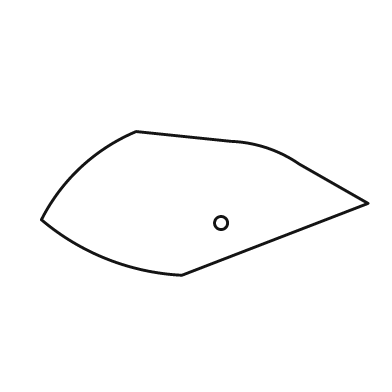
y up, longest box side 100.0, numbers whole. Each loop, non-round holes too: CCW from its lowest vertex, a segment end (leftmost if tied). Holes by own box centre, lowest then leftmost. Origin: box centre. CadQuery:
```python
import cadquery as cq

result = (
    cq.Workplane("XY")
    .moveTo(-7.0, -22.0)
    .lineTo(50.0, 0.0)
    .lineTo(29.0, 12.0)
    .threePointArc((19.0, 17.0), (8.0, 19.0))
    .lineTo(-21.0, 22.0)
    .threePointArc((-38.0, 11.0), (-50.0, -5.0))
    .threePointArc((-30.0, -17.0), (-7.0, -22.0))
    .close()
    .moveTo(5.0, -6.0)
    .circle(2.0)
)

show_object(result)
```